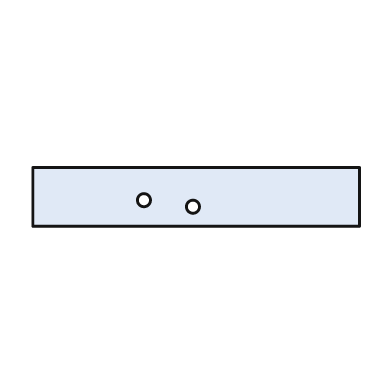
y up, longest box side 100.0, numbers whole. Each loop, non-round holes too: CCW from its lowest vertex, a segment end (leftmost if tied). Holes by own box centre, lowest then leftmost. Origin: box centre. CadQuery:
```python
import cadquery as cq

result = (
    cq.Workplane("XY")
    .moveTo(-50.0, -9.0)
    .lineTo(50.0, -9.0)
    .lineTo(50.0, 9.0)
    .lineTo(-50.0, 9.0)
    .close()
    .moveTo(-1.0, -3.0)
    .circle(2.0)
    .moveTo(-16.0, -1.0)
    .circle(2.0)
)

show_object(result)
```